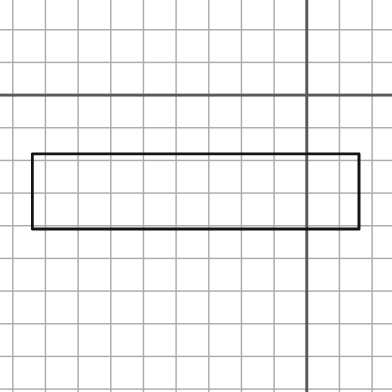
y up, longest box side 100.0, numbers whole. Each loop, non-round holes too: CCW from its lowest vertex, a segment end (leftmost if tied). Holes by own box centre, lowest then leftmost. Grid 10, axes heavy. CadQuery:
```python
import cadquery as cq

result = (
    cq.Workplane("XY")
    .moveTo(-84.0, -41.0)
    .lineTo(16.0, -41.0)
    .lineTo(16.0, -18.0)
    .lineTo(-84.0, -18.0)
    .close()
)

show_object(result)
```